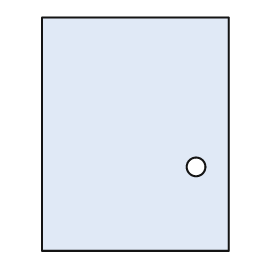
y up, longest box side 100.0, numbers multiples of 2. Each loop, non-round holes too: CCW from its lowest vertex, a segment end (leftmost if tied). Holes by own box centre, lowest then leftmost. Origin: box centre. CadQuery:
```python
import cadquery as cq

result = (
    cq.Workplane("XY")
    .moveTo(-40.0, -50.0)
    .lineTo(40.0, -50.0)
    .lineTo(40.0, 50.0)
    .lineTo(-40.0, 50.0)
    .close()
    .moveTo(26.0, -14.0)
    .circle(4.0)
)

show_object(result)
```